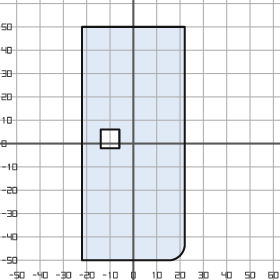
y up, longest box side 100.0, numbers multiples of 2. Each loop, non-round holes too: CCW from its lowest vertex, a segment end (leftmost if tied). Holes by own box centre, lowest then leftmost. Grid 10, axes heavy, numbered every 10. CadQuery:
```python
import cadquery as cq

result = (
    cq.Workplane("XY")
    .moveTo(-22.0, -50.0)
    .lineTo(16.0, -50.0)
    .threePointArc((20.0, -48.0), (22.0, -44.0))
    .lineTo(22.0, 50.0)
    .lineTo(-22.0, 50.0)
    .close()
    .moveTo(-14.0, -2.0)
    .lineTo(-6.0, -2.0)
    .lineTo(-6.0, 6.0)
    .lineTo(-14.0, 6.0)
    .close()
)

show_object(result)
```